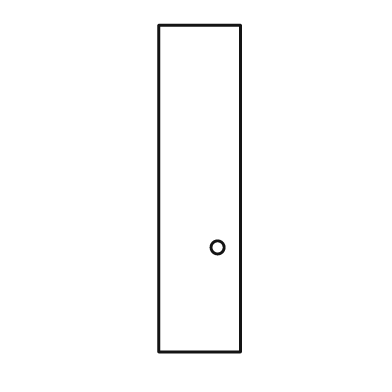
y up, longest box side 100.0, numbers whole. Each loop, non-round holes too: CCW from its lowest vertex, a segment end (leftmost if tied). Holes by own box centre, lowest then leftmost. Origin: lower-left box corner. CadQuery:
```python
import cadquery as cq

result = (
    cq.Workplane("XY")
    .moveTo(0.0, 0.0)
    .lineTo(25.0, 0.0)
    .lineTo(25.0, 100.0)
    .lineTo(0.0, 100.0)
    .close()
    .moveTo(18.0, 32.0)
    .circle(2.0)
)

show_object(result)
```